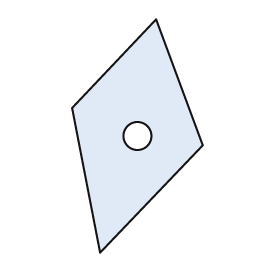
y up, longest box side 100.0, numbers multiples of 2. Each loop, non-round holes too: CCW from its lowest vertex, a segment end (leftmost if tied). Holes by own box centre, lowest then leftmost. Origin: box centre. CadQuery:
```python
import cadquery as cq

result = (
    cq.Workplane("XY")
    .moveTo(-16.0, -50.0)
    .lineTo(28.0, -4.0)
    .lineTo(8.0, 50.0)
    .lineTo(-28.0, 12.0)
    .close()
    .moveTo(0.0, 0.0)
    .circle(6.0)
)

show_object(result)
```